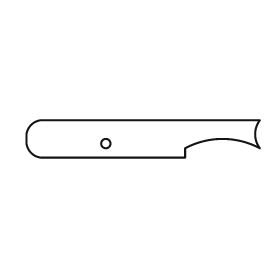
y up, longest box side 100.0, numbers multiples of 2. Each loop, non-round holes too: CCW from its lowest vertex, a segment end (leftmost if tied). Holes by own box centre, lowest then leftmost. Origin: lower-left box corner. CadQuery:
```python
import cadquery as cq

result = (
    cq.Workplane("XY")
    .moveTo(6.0, 0.0)
    .lineTo(68.0, 0.0)
    .lineTo(68.0, 4.0)
    .threePointArc((84.0, 8.0), (100.0, 4.0))
    .threePointArc((98.0, 10.0), (100.0, 16.0))
    .lineTo(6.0, 16.0)
    .threePointArc((2.0, 14.0), (0.0, 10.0))
    .lineTo(0.0, 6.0)
    .threePointArc((2.0, 2.0), (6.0, 0.0))
    .close()
    .moveTo(34.0, 6.0)
    .circle(2.0)
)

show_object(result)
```